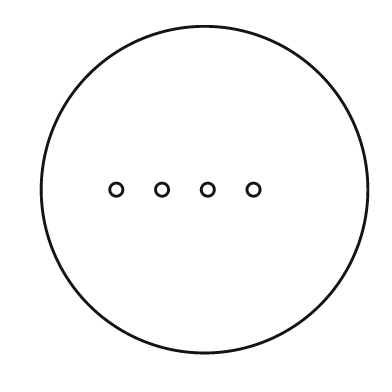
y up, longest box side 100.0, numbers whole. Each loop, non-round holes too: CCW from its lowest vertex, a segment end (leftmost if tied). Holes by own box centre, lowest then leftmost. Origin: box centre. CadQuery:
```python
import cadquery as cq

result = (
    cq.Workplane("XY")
    .moveTo(0.0, 0.0)
    .circle(50.0)
    .moveTo(-27.0, 0.0)
    .circle(2.0)
    .moveTo(-13.0, 0.0)
    .circle(2.0)
    .moveTo(1.0, 0.0)
    .circle(2.0)
    .moveTo(15.0, 0.0)
    .circle(2.0)
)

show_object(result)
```